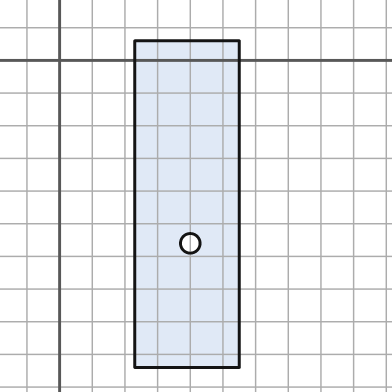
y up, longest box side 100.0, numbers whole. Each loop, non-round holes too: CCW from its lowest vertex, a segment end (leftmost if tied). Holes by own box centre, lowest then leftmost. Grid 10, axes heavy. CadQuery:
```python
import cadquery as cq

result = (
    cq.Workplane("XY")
    .moveTo(23.0, -94.0)
    .lineTo(55.0, -94.0)
    .lineTo(55.0, 6.0)
    .lineTo(23.0, 6.0)
    .close()
    .moveTo(40.0, -56.0)
    .circle(3.0)
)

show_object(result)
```